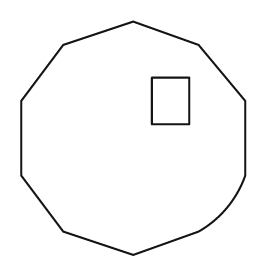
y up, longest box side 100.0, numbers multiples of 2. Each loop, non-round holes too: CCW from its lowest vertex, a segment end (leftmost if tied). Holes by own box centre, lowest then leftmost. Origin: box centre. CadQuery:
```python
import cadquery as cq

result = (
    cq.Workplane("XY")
    .moveTo(0.0, -50.0)
    .lineTo(28.0, -40.0)
    .threePointArc((40.0, -30.0), (48.0, -16.0))
    .lineTo(48.0, 16.0)
    .lineTo(28.0, 40.0)
    .lineTo(0.0, 50.0)
    .lineTo(-30.0, 40.0)
    .lineTo(-48.0, 16.0)
    .lineTo(-48.0, -16.0)
    .lineTo(-30.0, -40.0)
    .close()
    .moveTo(8.0, 6.0)
    .lineTo(24.0, 6.0)
    .lineTo(24.0, 26.0)
    .lineTo(8.0, 26.0)
    .close()
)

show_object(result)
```